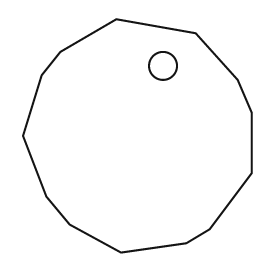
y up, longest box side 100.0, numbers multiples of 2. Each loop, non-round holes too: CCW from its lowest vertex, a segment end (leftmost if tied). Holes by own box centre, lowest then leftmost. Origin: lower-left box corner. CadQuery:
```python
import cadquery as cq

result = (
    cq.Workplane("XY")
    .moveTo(42.0, 0.0)
    .lineTo(70.0, 4.0)
    .lineTo(80.0, 10.0)
    .lineTo(98.0, 34.0)
    .lineTo(98.0, 60.0)
    .lineTo(92.0, 74.0)
    .lineTo(74.0, 94.0)
    .lineTo(40.0, 100.0)
    .lineTo(16.0, 86.0)
    .lineTo(8.0, 76.0)
    .lineTo(0.0, 50.0)
    .lineTo(10.0, 24.0)
    .lineTo(20.0, 12.0)
    .close()
    .moveTo(60.0, 80.0)
    .circle(6.0)
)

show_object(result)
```